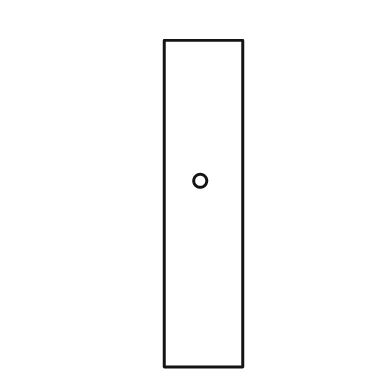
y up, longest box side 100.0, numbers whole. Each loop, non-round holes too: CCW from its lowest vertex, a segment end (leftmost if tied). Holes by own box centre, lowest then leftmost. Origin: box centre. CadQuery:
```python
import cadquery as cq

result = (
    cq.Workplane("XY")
    .moveTo(-12.0, -50.0)
    .lineTo(12.0, -50.0)
    .lineTo(12.0, 50.0)
    .lineTo(-12.0, 50.0)
    .close()
    .moveTo(-1.0, 7.0)
    .circle(2.0)
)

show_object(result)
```